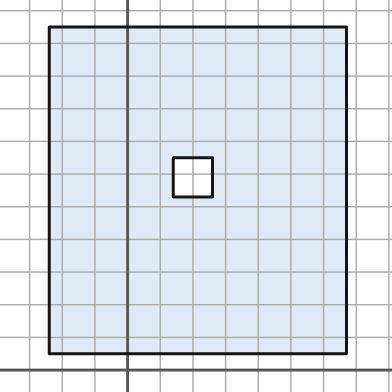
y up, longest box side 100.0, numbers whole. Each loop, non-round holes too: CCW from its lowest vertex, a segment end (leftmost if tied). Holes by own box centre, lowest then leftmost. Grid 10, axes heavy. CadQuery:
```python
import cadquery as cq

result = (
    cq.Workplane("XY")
    .moveTo(-24.0, 5.0)
    .lineTo(67.0, 5.0)
    .lineTo(67.0, 105.0)
    .lineTo(-24.0, 105.0)
    .close()
    .moveTo(14.0, 53.0)
    .lineTo(26.0, 53.0)
    .lineTo(26.0, 65.0)
    .lineTo(14.0, 65.0)
    .close()
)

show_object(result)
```